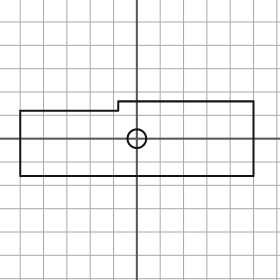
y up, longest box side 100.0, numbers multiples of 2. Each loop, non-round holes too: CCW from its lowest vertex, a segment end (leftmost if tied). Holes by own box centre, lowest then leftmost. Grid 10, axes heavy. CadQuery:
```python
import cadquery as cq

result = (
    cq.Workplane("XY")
    .moveTo(-50.0, -16.0)
    .lineTo(50.0, -16.0)
    .lineTo(50.0, 16.0)
    .lineTo(-8.0, 16.0)
    .lineTo(-8.0, 12.0)
    .lineTo(-50.0, 12.0)
    .close()
    .moveTo(0.0, 0.0)
    .circle(4.0)
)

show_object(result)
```